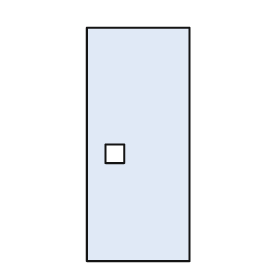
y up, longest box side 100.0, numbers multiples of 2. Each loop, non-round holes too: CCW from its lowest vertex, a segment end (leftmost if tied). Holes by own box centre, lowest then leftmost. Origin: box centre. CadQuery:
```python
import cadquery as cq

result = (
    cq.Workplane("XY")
    .moveTo(-22.0, -50.0)
    .lineTo(22.0, -50.0)
    .lineTo(22.0, 50.0)
    .lineTo(-22.0, 50.0)
    .close()
    .moveTo(-14.0, -8.0)
    .lineTo(-6.0, -8.0)
    .lineTo(-6.0, 0.0)
    .lineTo(-14.0, 0.0)
    .close()
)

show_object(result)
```